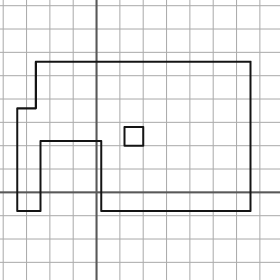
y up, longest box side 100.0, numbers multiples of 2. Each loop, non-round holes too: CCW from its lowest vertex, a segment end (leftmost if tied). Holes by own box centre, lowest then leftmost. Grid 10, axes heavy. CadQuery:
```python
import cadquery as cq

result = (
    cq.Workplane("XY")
    .moveTo(-34.0, -8.0)
    .lineTo(-24.0, -8.0)
    .lineTo(-24.0, 22.0)
    .lineTo(2.0, 22.0)
    .lineTo(2.0, -8.0)
    .lineTo(66.0, -8.0)
    .lineTo(66.0, 56.0)
    .lineTo(-26.0, 56.0)
    .lineTo(-26.0, 36.0)
    .lineTo(-34.0, 36.0)
    .close()
    .moveTo(12.0, 20.0)
    .lineTo(20.0, 20.0)
    .lineTo(20.0, 28.0)
    .lineTo(12.0, 28.0)
    .close()
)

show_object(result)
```